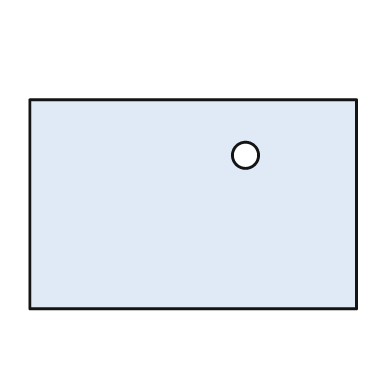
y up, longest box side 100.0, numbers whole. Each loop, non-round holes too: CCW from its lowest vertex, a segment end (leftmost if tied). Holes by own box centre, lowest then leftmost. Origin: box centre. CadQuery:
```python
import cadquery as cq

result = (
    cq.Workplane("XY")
    .moveTo(-50.0, -32.0)
    .lineTo(50.0, -32.0)
    .lineTo(50.0, 32.0)
    .lineTo(-50.0, 32.0)
    .close()
    .moveTo(16.0, 15.0)
    .circle(4.0)
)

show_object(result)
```